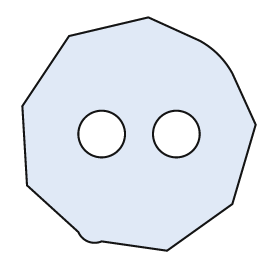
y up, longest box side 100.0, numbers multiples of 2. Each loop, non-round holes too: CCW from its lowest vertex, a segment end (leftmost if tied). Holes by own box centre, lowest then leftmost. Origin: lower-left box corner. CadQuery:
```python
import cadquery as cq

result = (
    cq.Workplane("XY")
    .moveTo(62.0, 0.0)
    .lineTo(90.0, 20.0)
    .lineTo(100.0, 54.0)
    .lineTo(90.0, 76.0)
    .threePointArc((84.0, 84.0), (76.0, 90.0))
    .lineTo(54.0, 100.0)
    .lineTo(20.0, 92.0)
    .lineTo(0.0, 62.0)
    .lineTo(2.0, 28.0)
    .lineTo(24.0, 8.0)
    .threePointArc((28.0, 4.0), (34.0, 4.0))
    .close()
    .moveTo(34.0, 50.0)
    .circle(10.0)
    .moveTo(66.0, 50.0)
    .circle(10.0)
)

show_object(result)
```